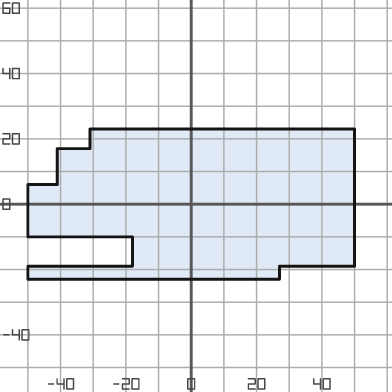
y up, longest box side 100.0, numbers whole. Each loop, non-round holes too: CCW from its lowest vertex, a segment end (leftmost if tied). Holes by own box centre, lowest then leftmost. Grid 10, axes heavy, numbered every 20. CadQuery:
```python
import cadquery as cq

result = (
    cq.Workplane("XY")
    .moveTo(-50.0, -23.0)
    .lineTo(27.0, -23.0)
    .lineTo(27.0, -19.0)
    .lineTo(50.0, -19.0)
    .lineTo(50.0, 23.0)
    .lineTo(-31.0, 23.0)
    .lineTo(-31.0, 17.0)
    .lineTo(-41.0, 17.0)
    .lineTo(-41.0, 6.0)
    .lineTo(-50.0, 6.0)
    .lineTo(-50.0, -10.0)
    .lineTo(-18.0, -10.0)
    .lineTo(-18.0, -19.0)
    .lineTo(-50.0, -19.0)
    .close()
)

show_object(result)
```